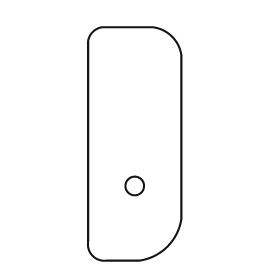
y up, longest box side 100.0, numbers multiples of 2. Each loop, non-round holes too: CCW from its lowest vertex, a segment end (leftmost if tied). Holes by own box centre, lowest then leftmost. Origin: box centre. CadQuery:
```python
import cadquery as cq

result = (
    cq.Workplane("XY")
    .moveTo(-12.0, -50.0)
    .lineTo(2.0, -50.0)
    .threePointArc((14.0, -44.0), (20.0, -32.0))
    .lineTo(20.0, 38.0)
    .threePointArc((16.0, 46.0), (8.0, 50.0))
    .lineTo(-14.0, 50.0)
    .threePointArc((-18.0, 48.0), (-20.0, 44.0))
    .lineTo(-20.0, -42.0)
    .threePointArc((-18.0, -48.0), (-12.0, -50.0))
    .close()
    .moveTo(0.0, -18.0)
    .circle(4.0)
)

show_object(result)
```